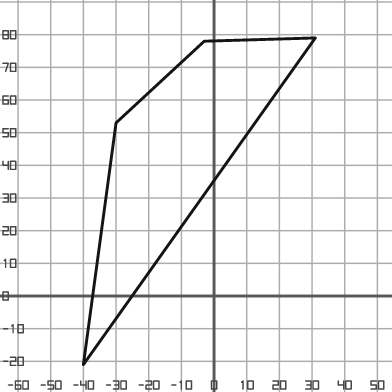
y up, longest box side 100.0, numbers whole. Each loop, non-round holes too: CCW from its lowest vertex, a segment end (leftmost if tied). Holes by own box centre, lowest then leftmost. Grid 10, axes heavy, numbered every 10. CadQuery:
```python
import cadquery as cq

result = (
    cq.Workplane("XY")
    .moveTo(-40.0, -21.0)
    .lineTo(31.0, 79.0)
    .lineTo(-3.0, 78.0)
    .lineTo(-30.0, 53.0)
    .close()
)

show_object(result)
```